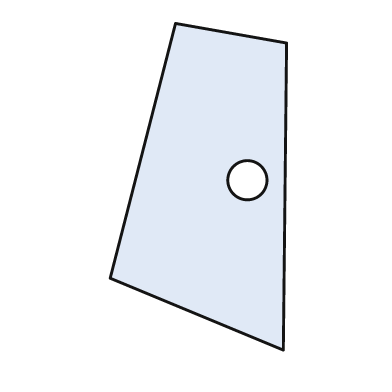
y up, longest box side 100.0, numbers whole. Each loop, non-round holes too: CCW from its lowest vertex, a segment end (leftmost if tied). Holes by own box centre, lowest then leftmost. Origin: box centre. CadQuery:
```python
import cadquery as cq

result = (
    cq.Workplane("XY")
    .moveTo(26.0, -50.0)
    .lineTo(27.0, 44.0)
    .lineTo(-7.0, 50.0)
    .lineTo(-27.0, -28.0)
    .close()
    .moveTo(15.0, 2.0)
    .circle(6.0)
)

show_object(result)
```